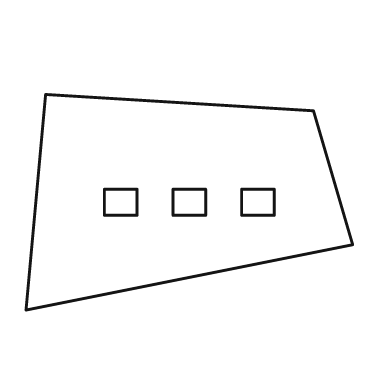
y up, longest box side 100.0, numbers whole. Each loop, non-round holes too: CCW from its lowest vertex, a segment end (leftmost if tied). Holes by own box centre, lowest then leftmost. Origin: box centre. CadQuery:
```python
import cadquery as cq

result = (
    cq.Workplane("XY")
    .moveTo(-50.0, -33.0)
    .lineTo(50.0, -13.0)
    .lineTo(38.0, 28.0)
    .lineTo(-44.0, 33.0)
    .close()
    .moveTo(-26.0, -4.0)
    .lineTo(-16.0, -4.0)
    .lineTo(-16.0, 4.0)
    .lineTo(-26.0, 4.0)
    .close()
    .moveTo(-5.0, -4.0)
    .lineTo(5.0, -4.0)
    .lineTo(5.0, 4.0)
    .lineTo(-5.0, 4.0)
    .close()
    .moveTo(16.0, -4.0)
    .lineTo(26.0, -4.0)
    .lineTo(26.0, 4.0)
    .lineTo(16.0, 4.0)
    .close()
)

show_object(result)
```